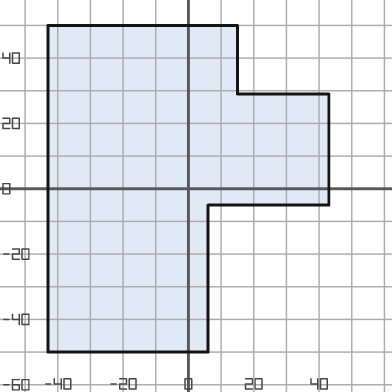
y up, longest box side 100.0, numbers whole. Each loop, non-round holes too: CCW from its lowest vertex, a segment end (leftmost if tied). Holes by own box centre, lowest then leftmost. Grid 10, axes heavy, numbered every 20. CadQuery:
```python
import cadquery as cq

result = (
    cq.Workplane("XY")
    .moveTo(-43.0, -50.0)
    .lineTo(6.0, -50.0)
    .lineTo(6.0, -5.0)
    .lineTo(43.0, -5.0)
    .lineTo(43.0, 29.0)
    .lineTo(15.0, 29.0)
    .lineTo(15.0, 50.0)
    .lineTo(-43.0, 50.0)
    .close()
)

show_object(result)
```